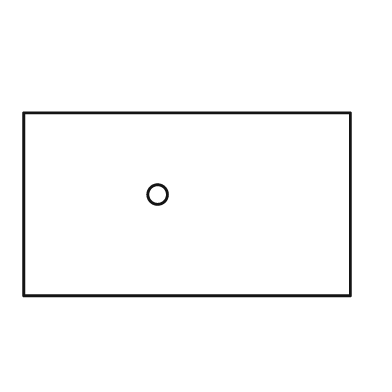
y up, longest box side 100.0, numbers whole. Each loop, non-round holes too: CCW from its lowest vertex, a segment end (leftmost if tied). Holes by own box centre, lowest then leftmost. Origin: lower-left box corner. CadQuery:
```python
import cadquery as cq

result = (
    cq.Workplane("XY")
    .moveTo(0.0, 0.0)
    .lineTo(100.0, 0.0)
    .lineTo(100.0, 56.0)
    .lineTo(0.0, 56.0)
    .close()
    .moveTo(41.0, 31.0)
    .circle(3.0)
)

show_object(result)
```